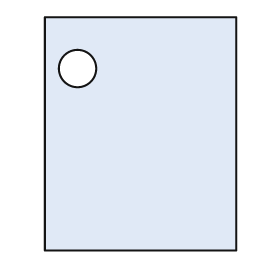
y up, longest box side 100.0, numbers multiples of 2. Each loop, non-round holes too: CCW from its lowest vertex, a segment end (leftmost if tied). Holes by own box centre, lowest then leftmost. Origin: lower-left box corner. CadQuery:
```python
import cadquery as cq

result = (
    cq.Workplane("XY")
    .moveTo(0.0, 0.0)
    .lineTo(82.0, 0.0)
    .lineTo(82.0, 100.0)
    .lineTo(0.0, 100.0)
    .close()
    .moveTo(14.0, 78.0)
    .circle(8.0)
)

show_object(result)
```